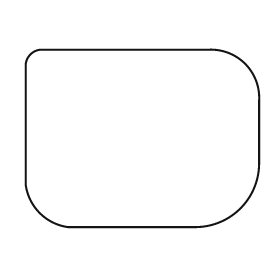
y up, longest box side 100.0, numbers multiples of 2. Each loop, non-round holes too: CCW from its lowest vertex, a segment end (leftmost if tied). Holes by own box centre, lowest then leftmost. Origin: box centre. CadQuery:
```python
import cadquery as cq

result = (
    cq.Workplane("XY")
    .moveTo(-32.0, -38.0)
    .lineTo(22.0, -38.0)
    .threePointArc((42.0, -30.0), (50.0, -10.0))
    .lineTo(50.0, 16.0)
    .threePointArc((44.0, 32.0), (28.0, 38.0))
    .lineTo(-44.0, 38.0)
    .threePointArc((-48.0, 36.0), (-50.0, 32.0))
    .lineTo(-50.0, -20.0)
    .threePointArc((-44.0, -32.0), (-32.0, -38.0))
    .close()
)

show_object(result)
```